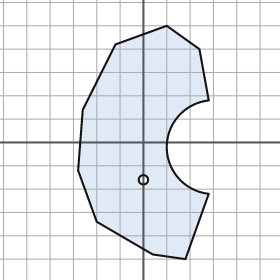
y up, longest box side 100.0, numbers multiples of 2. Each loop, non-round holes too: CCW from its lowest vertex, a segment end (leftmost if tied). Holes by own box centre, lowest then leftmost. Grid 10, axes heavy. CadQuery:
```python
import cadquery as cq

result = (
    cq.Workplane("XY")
    .moveTo(18.0, -50.0)
    .lineTo(28.0, -22.0)
    .threePointArc((10.0, -2.0), (28.0, 18.0))
    .lineTo(24.0, 40.0)
    .lineTo(10.0, 50.0)
    .lineTo(-12.0, 42.0)
    .lineTo(-26.0, 14.0)
    .lineTo(-28.0, -12.0)
    .lineTo(-20.0, -34.0)
    .lineTo(4.0, -48.0)
    .close()
    .moveTo(0.0, -16.0)
    .circle(2.0)
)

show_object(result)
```